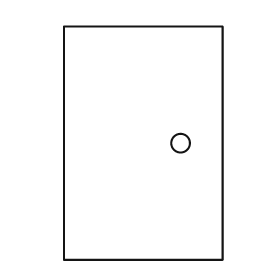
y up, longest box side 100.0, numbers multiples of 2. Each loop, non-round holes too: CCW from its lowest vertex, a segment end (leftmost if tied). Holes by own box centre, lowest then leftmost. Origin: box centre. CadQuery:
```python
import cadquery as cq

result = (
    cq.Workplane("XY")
    .moveTo(-34.0, -50.0)
    .lineTo(34.0, -50.0)
    .lineTo(34.0, 50.0)
    .lineTo(-34.0, 50.0)
    .close()
    .moveTo(16.0, 0.0)
    .circle(4.0)
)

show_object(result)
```